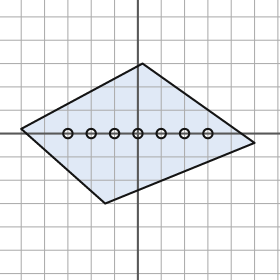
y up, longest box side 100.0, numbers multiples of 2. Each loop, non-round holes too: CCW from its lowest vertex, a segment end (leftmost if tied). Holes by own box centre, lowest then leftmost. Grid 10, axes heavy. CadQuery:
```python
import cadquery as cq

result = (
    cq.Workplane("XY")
    .moveTo(-14.0, -30.0)
    .lineTo(50.0, -4.0)
    .lineTo(2.0, 30.0)
    .lineTo(-50.0, 2.0)
    .close()
    .moveTo(-30.0, 0.0)
    .circle(2.0)
    .moveTo(-20.0, 0.0)
    .circle(2.0)
    .moveTo(-10.0, 0.0)
    .circle(2.0)
    .moveTo(0.0, 0.0)
    .circle(2.0)
    .moveTo(10.0, 0.0)
    .circle(2.0)
    .moveTo(20.0, 0.0)
    .circle(2.0)
    .moveTo(30.0, 0.0)
    .circle(2.0)
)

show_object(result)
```